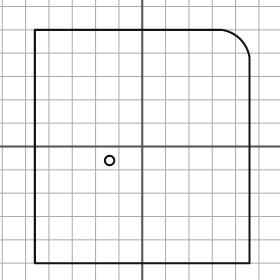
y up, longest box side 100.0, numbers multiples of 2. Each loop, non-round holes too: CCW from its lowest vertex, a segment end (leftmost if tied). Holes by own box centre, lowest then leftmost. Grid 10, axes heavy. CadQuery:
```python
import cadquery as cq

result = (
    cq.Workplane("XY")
    .moveTo(-46.0, -50.0)
    .lineTo(46.0, -50.0)
    .lineTo(46.0, 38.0)
    .threePointArc((42.0, 46.0), (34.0, 50.0))
    .lineTo(-46.0, 50.0)
    .close()
    .moveTo(-14.0, -6.0)
    .circle(2.0)
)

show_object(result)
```